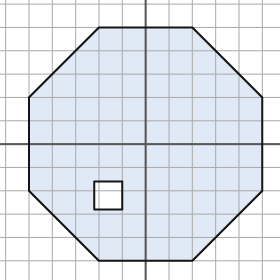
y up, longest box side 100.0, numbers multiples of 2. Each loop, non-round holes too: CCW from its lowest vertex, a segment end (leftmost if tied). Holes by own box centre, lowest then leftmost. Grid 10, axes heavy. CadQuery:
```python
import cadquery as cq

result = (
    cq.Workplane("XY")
    .moveTo(-20.0, -50.0)
    .lineTo(20.0, -50.0)
    .lineTo(50.0, -20.0)
    .lineTo(50.0, 20.0)
    .lineTo(20.0, 50.0)
    .lineTo(-20.0, 50.0)
    .lineTo(-50.0, 20.0)
    .lineTo(-50.0, -20.0)
    .close()
    .moveTo(-22.0, -28.0)
    .lineTo(-10.0, -28.0)
    .lineTo(-10.0, -16.0)
    .lineTo(-22.0, -16.0)
    .close()
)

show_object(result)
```